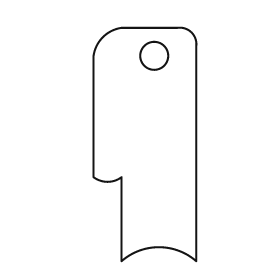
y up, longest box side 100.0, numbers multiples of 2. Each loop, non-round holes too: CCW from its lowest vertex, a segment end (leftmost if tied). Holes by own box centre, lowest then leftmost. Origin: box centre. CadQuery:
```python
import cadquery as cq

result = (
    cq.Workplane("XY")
    .moveTo(-10.0, -50.0)
    .threePointArc((6.0, -44.0), (22.0, -50.0))
    .lineTo(22.0, 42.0)
    .threePointArc((20.0, 48.0), (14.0, 50.0))
    .lineTo(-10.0, 50.0)
    .threePointArc((-18.0, 46.0), (-22.0, 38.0))
    .lineTo(-22.0, -14.0)
    .threePointArc((-16.0, -16.0), (-10.0, -14.0))
    .close()
    .moveTo(4.0, 38.0)
    .circle(6.0)
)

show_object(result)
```